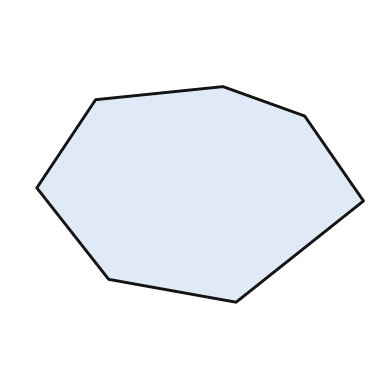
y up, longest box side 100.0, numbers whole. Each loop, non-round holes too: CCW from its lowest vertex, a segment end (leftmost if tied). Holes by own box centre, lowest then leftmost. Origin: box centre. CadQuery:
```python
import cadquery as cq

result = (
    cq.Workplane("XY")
    .moveTo(11.0, -33.0)
    .lineTo(50.0, -2.0)
    .lineTo(32.0, 24.0)
    .lineTo(7.0, 33.0)
    .lineTo(-32.0, 29.0)
    .lineTo(-50.0, 2.0)
    .lineTo(-28.0, -26.0)
    .close()
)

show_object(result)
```